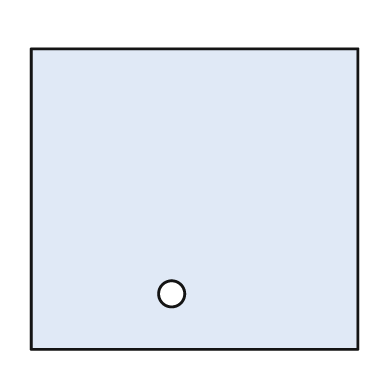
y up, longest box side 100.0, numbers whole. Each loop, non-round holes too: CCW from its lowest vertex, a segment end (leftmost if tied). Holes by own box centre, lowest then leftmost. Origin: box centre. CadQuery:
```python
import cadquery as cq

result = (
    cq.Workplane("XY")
    .moveTo(-50.0, -46.0)
    .lineTo(50.0, -46.0)
    .lineTo(50.0, 46.0)
    .lineTo(-50.0, 46.0)
    .close()
    .moveTo(-7.0, -29.0)
    .circle(4.0)
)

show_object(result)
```